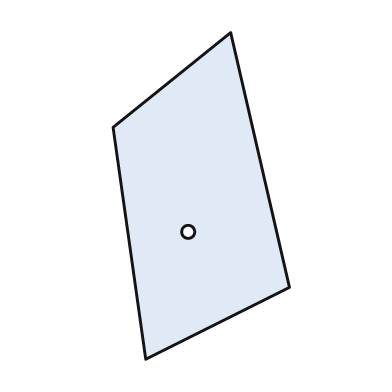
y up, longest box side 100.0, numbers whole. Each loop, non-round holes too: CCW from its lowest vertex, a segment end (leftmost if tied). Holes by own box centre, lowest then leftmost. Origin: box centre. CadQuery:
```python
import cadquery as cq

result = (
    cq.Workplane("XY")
    .moveTo(-17.0, -50.0)
    .lineTo(27.0, -28.0)
    .lineTo(9.0, 50.0)
    .lineTo(-27.0, 21.0)
    .close()
    .moveTo(-4.0, -11.0)
    .circle(2.0)
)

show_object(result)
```